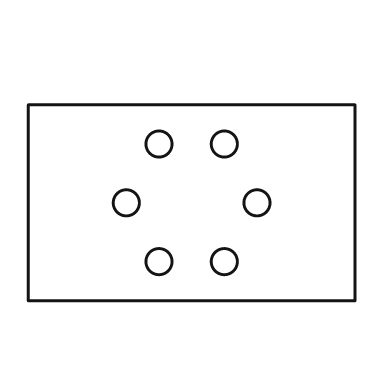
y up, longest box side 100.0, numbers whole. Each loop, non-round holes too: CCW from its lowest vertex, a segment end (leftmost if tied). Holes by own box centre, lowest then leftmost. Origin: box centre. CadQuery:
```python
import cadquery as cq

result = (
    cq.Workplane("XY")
    .moveTo(-50.0, -30.0)
    .lineTo(50.0, -30.0)
    .lineTo(50.0, 30.0)
    .lineTo(-50.0, 30.0)
    .close()
    .moveTo(-10.0, -18.0)
    .circle(4.0)
    .moveTo(10.0, -18.0)
    .circle(4.0)
    .moveTo(-20.0, 0.0)
    .circle(4.0)
    .moveTo(20.0, 0.0)
    .circle(4.0)
    .moveTo(-10.0, 18.0)
    .circle(4.0)
    .moveTo(10.0, 18.0)
    .circle(4.0)
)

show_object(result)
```